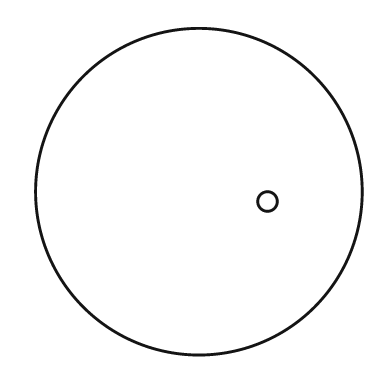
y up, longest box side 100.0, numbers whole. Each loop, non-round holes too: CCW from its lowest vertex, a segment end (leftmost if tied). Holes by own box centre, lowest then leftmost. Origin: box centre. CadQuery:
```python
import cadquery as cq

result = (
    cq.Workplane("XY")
    .moveTo(0.0, 0.0)
    .circle(50.0)
    .moveTo(21.0, -3.0)
    .circle(3.0)
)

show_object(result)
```